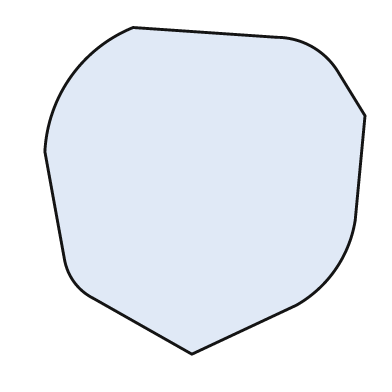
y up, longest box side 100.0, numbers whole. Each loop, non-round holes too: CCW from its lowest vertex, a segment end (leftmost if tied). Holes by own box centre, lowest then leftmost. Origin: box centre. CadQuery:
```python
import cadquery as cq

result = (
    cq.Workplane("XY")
    .moveTo(-4.0, -50.0)
    .lineTo(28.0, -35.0)
    .threePointArc((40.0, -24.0), (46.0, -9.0))
    .lineTo(49.0, 23.0)
    .lineTo(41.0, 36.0)
    .threePointArc((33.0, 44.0), (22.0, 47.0))
    .lineTo(-22.0, 50.0)
    .threePointArc((-41.0, 35.0), (-49.0, 12.0))
    .lineTo(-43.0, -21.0)
    .threePointArc((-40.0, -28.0), (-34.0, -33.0))
    .close()
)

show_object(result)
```